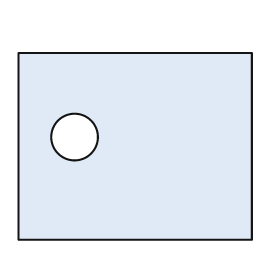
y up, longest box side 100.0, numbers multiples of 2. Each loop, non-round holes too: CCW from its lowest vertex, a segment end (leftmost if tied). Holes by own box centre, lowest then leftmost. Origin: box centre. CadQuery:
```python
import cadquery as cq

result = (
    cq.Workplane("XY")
    .moveTo(-50.0, -40.0)
    .lineTo(50.0, -40.0)
    .lineTo(50.0, 40.0)
    .lineTo(-50.0, 40.0)
    .close()
    .moveTo(-26.0, 4.0)
    .circle(10.0)
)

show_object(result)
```